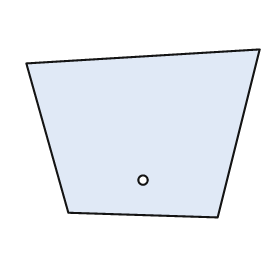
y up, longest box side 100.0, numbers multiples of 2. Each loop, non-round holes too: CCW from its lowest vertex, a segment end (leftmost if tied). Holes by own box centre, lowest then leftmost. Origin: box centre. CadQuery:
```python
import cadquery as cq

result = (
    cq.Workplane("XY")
    .moveTo(32.0, -36.0)
    .lineTo(50.0, 36.0)
    .lineTo(-50.0, 30.0)
    .lineTo(-32.0, -34.0)
    .close()
    .moveTo(0.0, -20.0)
    .circle(2.0)
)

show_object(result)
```